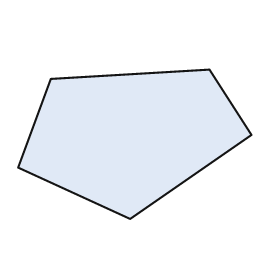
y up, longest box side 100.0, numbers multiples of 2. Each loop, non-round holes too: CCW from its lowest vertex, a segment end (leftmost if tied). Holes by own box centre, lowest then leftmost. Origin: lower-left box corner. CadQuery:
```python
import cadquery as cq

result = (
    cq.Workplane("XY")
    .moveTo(48.0, 0.0)
    .lineTo(100.0, 36.0)
    .lineTo(82.0, 64.0)
    .lineTo(14.0, 60.0)
    .lineTo(0.0, 22.0)
    .close()
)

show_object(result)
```